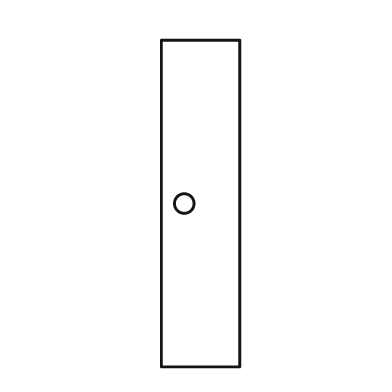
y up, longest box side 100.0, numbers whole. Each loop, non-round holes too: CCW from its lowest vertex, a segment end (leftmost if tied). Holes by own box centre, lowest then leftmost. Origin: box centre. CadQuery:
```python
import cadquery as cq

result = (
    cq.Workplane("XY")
    .moveTo(-12.0, -50.0)
    .lineTo(12.0, -50.0)
    .lineTo(12.0, 50.0)
    .lineTo(-12.0, 50.0)
    .close()
    .moveTo(-5.0, 0.0)
    .circle(3.0)
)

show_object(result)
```